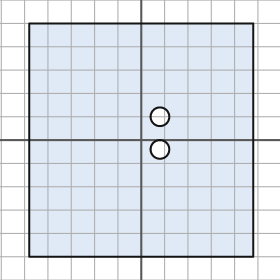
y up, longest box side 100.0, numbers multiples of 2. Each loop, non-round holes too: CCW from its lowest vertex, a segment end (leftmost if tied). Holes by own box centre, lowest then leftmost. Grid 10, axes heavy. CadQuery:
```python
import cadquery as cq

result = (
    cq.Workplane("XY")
    .moveTo(-48.0, -50.0)
    .lineTo(48.0, -50.0)
    .lineTo(48.0, 50.0)
    .lineTo(-48.0, 50.0)
    .close()
    .moveTo(8.0, -4.0)
    .circle(4.0)
    .moveTo(8.0, 10.0)
    .circle(4.0)
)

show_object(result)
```